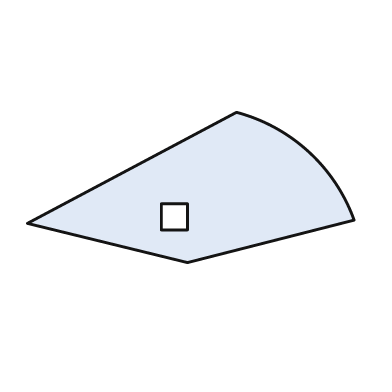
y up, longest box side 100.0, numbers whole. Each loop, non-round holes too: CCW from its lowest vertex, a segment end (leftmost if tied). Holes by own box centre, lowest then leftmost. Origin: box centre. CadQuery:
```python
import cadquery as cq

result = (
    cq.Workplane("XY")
    .moveTo(-1.0, -23.0)
    .lineTo(50.0, -10.0)
    .threePointArc((36.0, 11.0), (14.0, 23.0))
    .lineTo(-50.0, -11.0)
    .close()
    .moveTo(-9.0, -13.0)
    .lineTo(-1.0, -13.0)
    .lineTo(-1.0, -5.0)
    .lineTo(-9.0, -5.0)
    .close()
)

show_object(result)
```